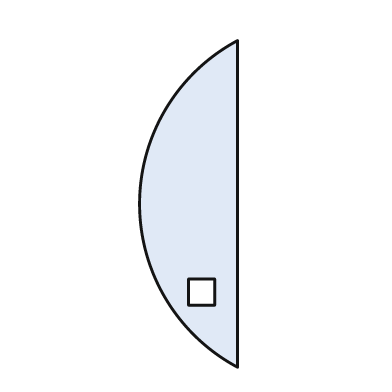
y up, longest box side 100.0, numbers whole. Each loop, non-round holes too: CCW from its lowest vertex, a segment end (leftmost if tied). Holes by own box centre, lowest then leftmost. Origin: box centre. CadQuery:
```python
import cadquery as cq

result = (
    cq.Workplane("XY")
    .moveTo(15.0, -50.0)
    .lineTo(15.0, 50.0)
    .threePointArc((-15.0, 0.0), (15.0, -50.0))
    .close()
    .moveTo(0.0, -31.0)
    .lineTo(8.0, -31.0)
    .lineTo(8.0, -23.0)
    .lineTo(0.0, -23.0)
    .close()
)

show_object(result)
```